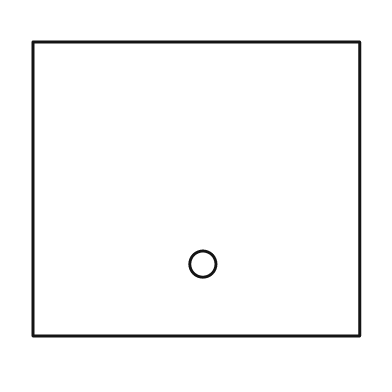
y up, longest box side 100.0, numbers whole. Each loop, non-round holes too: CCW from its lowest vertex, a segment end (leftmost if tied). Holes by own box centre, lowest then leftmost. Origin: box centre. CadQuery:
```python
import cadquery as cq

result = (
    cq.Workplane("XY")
    .moveTo(-50.0, -45.0)
    .lineTo(50.0, -45.0)
    .lineTo(50.0, 45.0)
    .lineTo(-50.0, 45.0)
    .close()
    .moveTo(2.0, -23.0)
    .circle(4.0)
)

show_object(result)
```